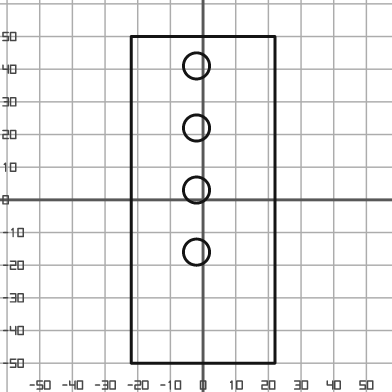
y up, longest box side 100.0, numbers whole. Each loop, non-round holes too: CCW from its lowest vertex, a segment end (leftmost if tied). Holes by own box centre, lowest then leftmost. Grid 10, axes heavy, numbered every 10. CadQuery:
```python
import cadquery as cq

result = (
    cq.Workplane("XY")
    .moveTo(-22.0, -50.0)
    .lineTo(22.0, -50.0)
    .lineTo(22.0, 50.0)
    .lineTo(-22.0, 50.0)
    .close()
    .moveTo(-2.0, -16.0)
    .circle(4.0)
    .moveTo(-2.0, 3.0)
    .circle(4.0)
    .moveTo(-2.0, 22.0)
    .circle(4.0)
    .moveTo(-2.0, 41.0)
    .circle(4.0)
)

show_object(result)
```